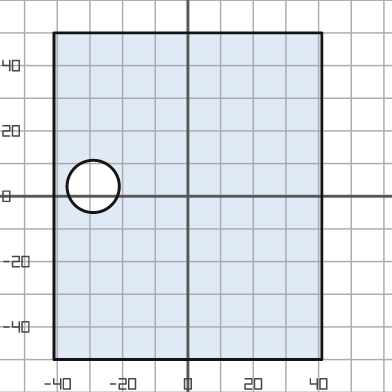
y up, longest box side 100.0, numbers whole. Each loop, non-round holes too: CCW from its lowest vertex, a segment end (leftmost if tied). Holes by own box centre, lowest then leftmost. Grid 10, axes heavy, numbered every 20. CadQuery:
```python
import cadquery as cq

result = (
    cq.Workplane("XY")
    .moveTo(-41.0, -50.0)
    .lineTo(41.0, -50.0)
    .lineTo(41.0, 50.0)
    .lineTo(-41.0, 50.0)
    .close()
    .moveTo(-29.0, 3.0)
    .circle(8.0)
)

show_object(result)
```